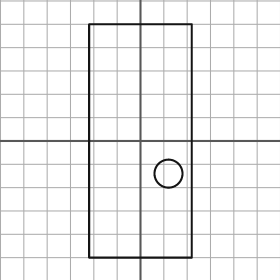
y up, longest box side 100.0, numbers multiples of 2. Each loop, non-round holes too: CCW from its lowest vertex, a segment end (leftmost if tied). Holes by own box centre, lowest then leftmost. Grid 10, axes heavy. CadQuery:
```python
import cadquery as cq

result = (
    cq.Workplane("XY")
    .moveTo(-22.0, -50.0)
    .lineTo(22.0, -50.0)
    .lineTo(22.0, 50.0)
    .lineTo(-22.0, 50.0)
    .close()
    .moveTo(12.0, -14.0)
    .circle(6.0)
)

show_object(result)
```